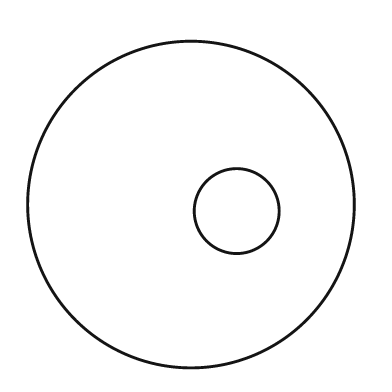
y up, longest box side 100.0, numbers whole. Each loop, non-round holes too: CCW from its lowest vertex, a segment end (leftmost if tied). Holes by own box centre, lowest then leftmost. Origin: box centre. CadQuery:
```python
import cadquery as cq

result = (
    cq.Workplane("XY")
    .moveTo(0.0, 0.0)
    .circle(50.0)
    .moveTo(14.0, -2.0)
    .circle(13.0)
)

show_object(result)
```